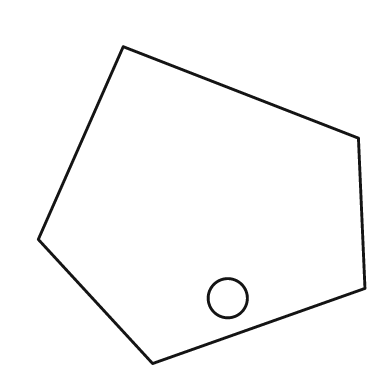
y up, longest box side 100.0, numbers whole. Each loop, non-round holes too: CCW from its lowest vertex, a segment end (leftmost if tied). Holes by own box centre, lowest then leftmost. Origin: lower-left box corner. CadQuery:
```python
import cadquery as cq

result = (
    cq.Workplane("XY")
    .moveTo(35.0, 0.0)
    .lineTo(100.0, 23.0)
    .lineTo(98.0, 69.0)
    .lineTo(26.0, 97.0)
    .lineTo(0.0, 38.0)
    .close()
    .moveTo(58.0, 20.0)
    .circle(6.0)
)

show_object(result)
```